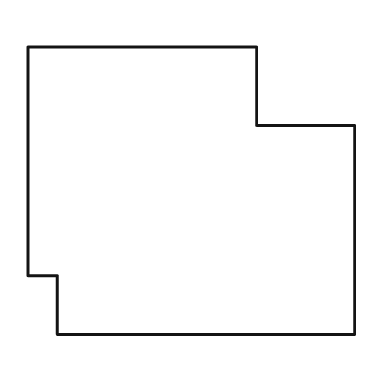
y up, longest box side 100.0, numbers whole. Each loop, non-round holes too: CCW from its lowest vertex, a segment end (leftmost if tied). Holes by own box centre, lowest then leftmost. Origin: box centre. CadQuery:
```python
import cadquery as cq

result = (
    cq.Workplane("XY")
    .moveTo(-41.0, -44.0)
    .lineTo(50.0, -44.0)
    .lineTo(50.0, 20.0)
    .lineTo(20.0, 20.0)
    .lineTo(20.0, 44.0)
    .lineTo(-50.0, 44.0)
    .lineTo(-50.0, -26.0)
    .lineTo(-41.0, -26.0)
    .close()
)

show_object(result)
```